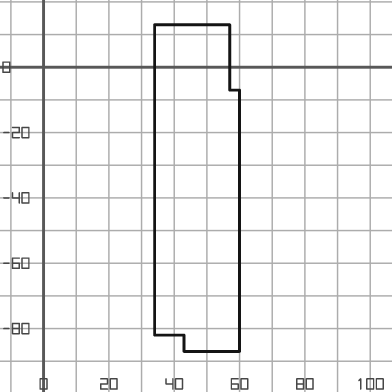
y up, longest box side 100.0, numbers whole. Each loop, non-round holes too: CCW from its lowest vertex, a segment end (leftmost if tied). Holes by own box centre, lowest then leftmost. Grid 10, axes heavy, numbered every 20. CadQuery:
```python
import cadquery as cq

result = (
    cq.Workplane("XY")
    .moveTo(43.0, -87.0)
    .lineTo(60.0, -87.0)
    .lineTo(60.0, -7.0)
    .lineTo(57.0, -7.0)
    .lineTo(57.0, 13.0)
    .lineTo(34.0, 13.0)
    .lineTo(34.0, -82.0)
    .lineTo(43.0, -82.0)
    .close()
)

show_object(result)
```